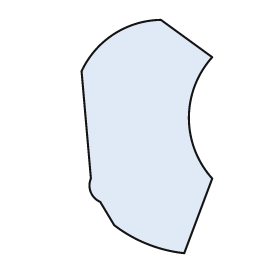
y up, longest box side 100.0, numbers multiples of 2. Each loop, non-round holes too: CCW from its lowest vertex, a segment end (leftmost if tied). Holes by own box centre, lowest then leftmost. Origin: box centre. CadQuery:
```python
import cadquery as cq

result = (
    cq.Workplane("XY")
    .moveTo(16.0, -50.0)
    .lineTo(28.0, -18.0)
    .threePointArc((18.0, 8.0), (28.0, 34.0))
    .lineTo(6.0, 50.0)
    .threePointArc((-14.0, 44.0), (-28.0, 28.0))
    .lineTo(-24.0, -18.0)
    .threePointArc((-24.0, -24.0), (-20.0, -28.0))
    .lineTo(-14.0, -38.0)
    .threePointArc((0.0, -46.0), (16.0, -50.0))
    .close()
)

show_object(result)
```